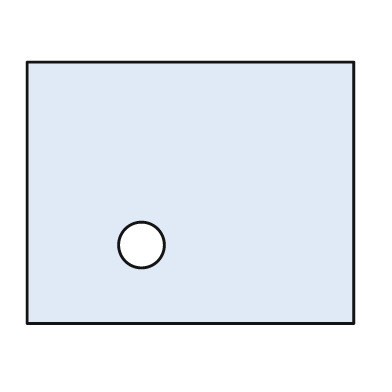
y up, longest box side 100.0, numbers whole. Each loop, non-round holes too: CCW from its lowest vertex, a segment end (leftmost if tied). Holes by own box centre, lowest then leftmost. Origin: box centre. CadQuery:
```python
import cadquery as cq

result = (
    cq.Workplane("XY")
    .moveTo(-50.0, -40.0)
    .lineTo(50.0, -40.0)
    .lineTo(50.0, 40.0)
    .lineTo(-50.0, 40.0)
    .close()
    .moveTo(-15.0, -16.0)
    .circle(7.0)
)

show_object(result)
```